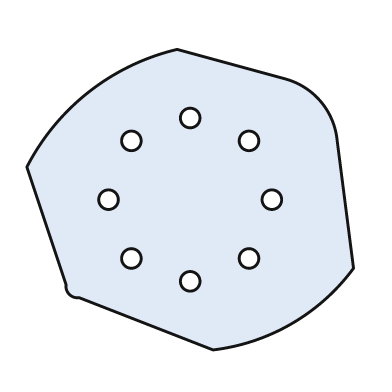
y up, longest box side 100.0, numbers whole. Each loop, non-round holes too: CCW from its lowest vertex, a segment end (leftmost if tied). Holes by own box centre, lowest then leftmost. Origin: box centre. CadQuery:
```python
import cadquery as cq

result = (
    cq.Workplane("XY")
    .moveTo(7.0, -46.0)
    .threePointArc((31.0, -38.0), (50.0, -21.0))
    .lineTo(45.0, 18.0)
    .threePointArc((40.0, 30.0), (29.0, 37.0))
    .lineTo(-4.0, 46.0)
    .threePointArc((-31.0, 33.0), (-50.0, 10.0))
    .lineTo(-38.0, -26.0)
    .threePointArc((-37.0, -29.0), (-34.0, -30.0))
    .close()
    .moveTo(0.0, -25.0)
    .circle(3.0)
    .moveTo(-18.0, -18.0)
    .circle(3.0)
    .moveTo(18.0, -18.0)
    .circle(3.0)
    .moveTo(-25.0, 0.0)
    .circle(3.0)
    .moveTo(25.0, 0.0)
    .circle(3.0)
    .moveTo(-18.0, 18.0)
    .circle(3.0)
    .moveTo(18.0, 18.0)
    .circle(3.0)
    .moveTo(0.0, 25.0)
    .circle(3.0)
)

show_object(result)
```